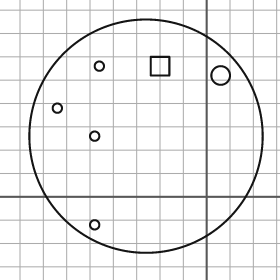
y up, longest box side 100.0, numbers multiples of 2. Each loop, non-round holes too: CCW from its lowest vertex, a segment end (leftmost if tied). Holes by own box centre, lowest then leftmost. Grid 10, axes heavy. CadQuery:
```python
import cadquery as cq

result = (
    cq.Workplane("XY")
    .moveTo(-26.0, 26.0)
    .circle(50.0)
    .moveTo(-48.0, -12.0)
    .circle(2.0)
    .moveTo(-48.0, 26.0)
    .circle(2.0)
    .moveTo(-64.0, 38.0)
    .circle(2.0)
    .moveTo(6.0, 52.0)
    .circle(4.0)
    .moveTo(-46.0, 56.0)
    .circle(2.0)
    .moveTo(-24.0, 52.0)
    .lineTo(-16.0, 52.0)
    .lineTo(-16.0, 60.0)
    .lineTo(-24.0, 60.0)
    .close()
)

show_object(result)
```